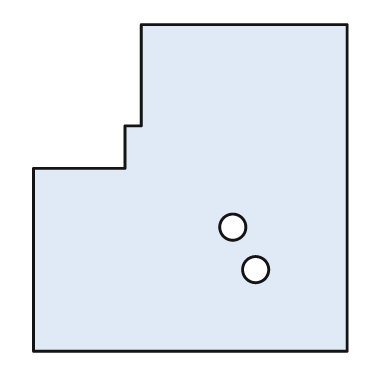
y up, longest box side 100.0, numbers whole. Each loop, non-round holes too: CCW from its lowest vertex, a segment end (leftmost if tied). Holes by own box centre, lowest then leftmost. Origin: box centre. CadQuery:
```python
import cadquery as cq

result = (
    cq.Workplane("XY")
    .moveTo(-48.0, -50.0)
    .lineTo(48.0, -50.0)
    .lineTo(48.0, 50.0)
    .lineTo(-15.0, 50.0)
    .lineTo(-15.0, 19.0)
    .lineTo(-20.0, 19.0)
    .lineTo(-20.0, 6.0)
    .lineTo(-48.0, 6.0)
    .close()
    .moveTo(20.0, -25.0)
    .circle(4.0)
    .moveTo(13.0, -12.0)
    .circle(4.0)
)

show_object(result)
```